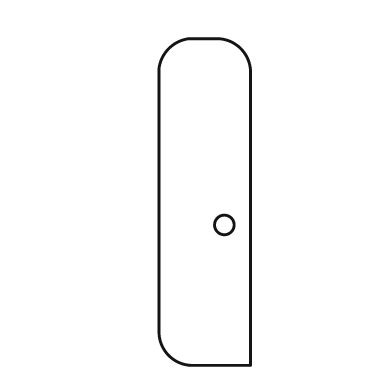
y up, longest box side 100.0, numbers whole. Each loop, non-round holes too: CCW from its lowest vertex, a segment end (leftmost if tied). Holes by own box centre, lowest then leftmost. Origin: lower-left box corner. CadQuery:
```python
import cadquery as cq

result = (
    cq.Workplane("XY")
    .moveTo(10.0, 0.0)
    .lineTo(28.0, 0.0)
    .lineTo(28.0, 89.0)
    .threePointArc((25.0, 97.0), (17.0, 100.0))
    .lineTo(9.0, 100.0)
    .threePointArc((3.0, 97.0), (0.0, 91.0))
    .lineTo(0.0, 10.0)
    .threePointArc((3.0, 3.0), (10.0, 0.0))
    .close()
    .moveTo(20.0, 43.0)
    .circle(3.0)
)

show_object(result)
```